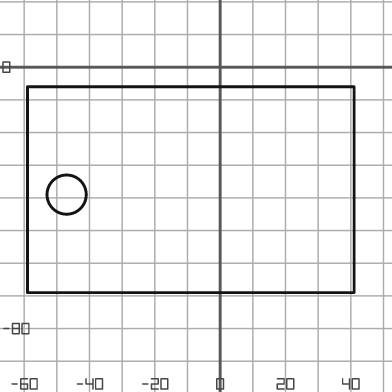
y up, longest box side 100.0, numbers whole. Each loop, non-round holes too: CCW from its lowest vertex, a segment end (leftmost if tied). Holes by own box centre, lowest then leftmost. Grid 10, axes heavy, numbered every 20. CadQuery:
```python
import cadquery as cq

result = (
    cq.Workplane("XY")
    .moveTo(-59.0, -69.0)
    .lineTo(41.0, -69.0)
    .lineTo(41.0, -6.0)
    .lineTo(-59.0, -6.0)
    .close()
    .moveTo(-47.0, -39.0)
    .circle(6.0)
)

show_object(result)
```